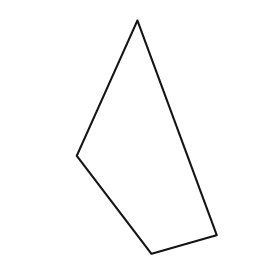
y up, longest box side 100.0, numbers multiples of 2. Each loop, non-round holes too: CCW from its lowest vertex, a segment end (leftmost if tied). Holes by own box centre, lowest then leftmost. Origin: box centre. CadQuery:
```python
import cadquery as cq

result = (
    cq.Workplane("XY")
    .moveTo(2.0, -50.0)
    .lineTo(30.0, -42.0)
    .lineTo(-4.0, 50.0)
    .lineTo(-30.0, -8.0)
    .close()
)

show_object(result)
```